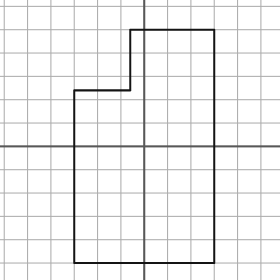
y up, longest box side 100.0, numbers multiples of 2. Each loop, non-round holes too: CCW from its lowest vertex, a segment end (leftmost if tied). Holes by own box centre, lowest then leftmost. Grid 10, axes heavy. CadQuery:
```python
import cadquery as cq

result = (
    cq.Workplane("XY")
    .moveTo(-30.0, -50.0)
    .lineTo(30.0, -50.0)
    .lineTo(30.0, 50.0)
    .lineTo(-6.0, 50.0)
    .lineTo(-6.0, 24.0)
    .lineTo(-30.0, 24.0)
    .close()
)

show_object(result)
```